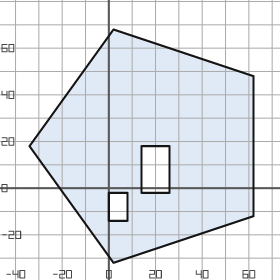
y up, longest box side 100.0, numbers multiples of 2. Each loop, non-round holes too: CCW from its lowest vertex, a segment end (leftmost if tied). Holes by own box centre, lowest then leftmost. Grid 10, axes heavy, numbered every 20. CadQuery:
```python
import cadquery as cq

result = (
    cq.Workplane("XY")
    .moveTo(2.0, -32.0)
    .lineTo(62.0, -12.0)
    .lineTo(62.0, 48.0)
    .lineTo(2.0, 68.0)
    .lineTo(-34.0, 18.0)
    .close()
    .moveTo(0.0, -14.0)
    .lineTo(8.0, -14.0)
    .lineTo(8.0, -2.0)
    .lineTo(0.0, -2.0)
    .close()
    .moveTo(14.0, -2.0)
    .lineTo(26.0, -2.0)
    .lineTo(26.0, 18.0)
    .lineTo(14.0, 18.0)
    .close()
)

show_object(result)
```